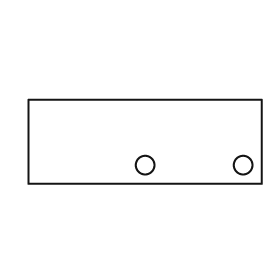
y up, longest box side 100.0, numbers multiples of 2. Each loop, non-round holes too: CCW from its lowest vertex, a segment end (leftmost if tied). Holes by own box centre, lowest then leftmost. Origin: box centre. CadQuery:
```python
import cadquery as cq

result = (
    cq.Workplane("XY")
    .moveTo(-50.0, -18.0)
    .lineTo(50.0, -18.0)
    .lineTo(50.0, 18.0)
    .lineTo(-50.0, 18.0)
    .close()
    .moveTo(0.0, -10.0)
    .circle(4.0)
    .moveTo(42.0, -10.0)
    .circle(4.0)
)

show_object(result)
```